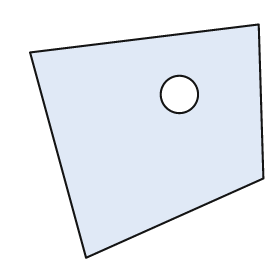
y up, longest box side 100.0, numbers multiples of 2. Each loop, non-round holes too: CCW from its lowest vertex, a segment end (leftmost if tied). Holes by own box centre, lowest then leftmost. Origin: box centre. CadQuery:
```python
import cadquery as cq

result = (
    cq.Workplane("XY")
    .moveTo(-26.0, -50.0)
    .lineTo(50.0, -16.0)
    .lineTo(48.0, 50.0)
    .lineTo(-50.0, 38.0)
    .close()
    .moveTo(14.0, 20.0)
    .circle(8.0)
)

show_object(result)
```